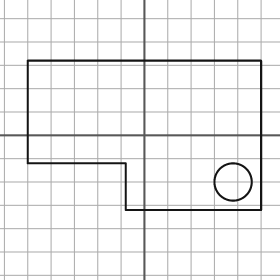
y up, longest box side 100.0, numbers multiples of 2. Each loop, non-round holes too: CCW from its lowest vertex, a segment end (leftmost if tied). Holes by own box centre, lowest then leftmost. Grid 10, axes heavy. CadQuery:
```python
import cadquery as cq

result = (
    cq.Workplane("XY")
    .moveTo(-8.0, -32.0)
    .lineTo(50.0, -32.0)
    .lineTo(50.0, 32.0)
    .lineTo(-50.0, 32.0)
    .lineTo(-50.0, -12.0)
    .lineTo(-8.0, -12.0)
    .close()
    .moveTo(38.0, -20.0)
    .circle(8.0)
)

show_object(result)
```